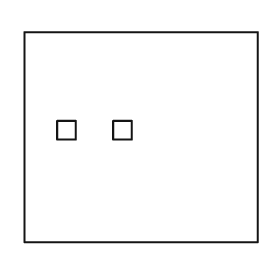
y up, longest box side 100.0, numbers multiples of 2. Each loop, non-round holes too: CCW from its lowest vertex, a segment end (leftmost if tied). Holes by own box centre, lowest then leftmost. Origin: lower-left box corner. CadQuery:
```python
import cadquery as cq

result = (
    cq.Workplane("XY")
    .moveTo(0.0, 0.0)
    .lineTo(100.0, 0.0)
    .lineTo(100.0, 90.0)
    .lineTo(0.0, 90.0)
    .close()
    .moveTo(14.0, 44.0)
    .lineTo(22.0, 44.0)
    .lineTo(22.0, 52.0)
    .lineTo(14.0, 52.0)
    .close()
    .moveTo(38.0, 44.0)
    .lineTo(46.0, 44.0)
    .lineTo(46.0, 52.0)
    .lineTo(38.0, 52.0)
    .close()
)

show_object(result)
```